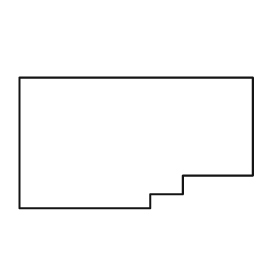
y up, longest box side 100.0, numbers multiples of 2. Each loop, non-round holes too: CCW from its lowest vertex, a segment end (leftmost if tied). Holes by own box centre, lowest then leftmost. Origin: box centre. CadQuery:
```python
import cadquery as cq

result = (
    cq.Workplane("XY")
    .moveTo(-50.0, -28.0)
    .lineTo(6.0, -28.0)
    .lineTo(6.0, -22.0)
    .lineTo(20.0, -22.0)
    .lineTo(20.0, -14.0)
    .lineTo(50.0, -14.0)
    .lineTo(50.0, 28.0)
    .lineTo(-50.0, 28.0)
    .close()
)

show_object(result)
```